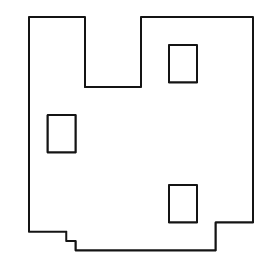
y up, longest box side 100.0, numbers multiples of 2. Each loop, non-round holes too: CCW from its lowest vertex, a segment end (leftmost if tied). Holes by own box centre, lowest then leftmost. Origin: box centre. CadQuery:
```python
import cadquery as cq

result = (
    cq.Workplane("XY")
    .moveTo(-28.0, -50.0)
    .lineTo(32.0, -50.0)
    .lineTo(32.0, -38.0)
    .lineTo(48.0, -38.0)
    .lineTo(48.0, 50.0)
    .lineTo(0.0, 50.0)
    .lineTo(0.0, 20.0)
    .lineTo(-24.0, 20.0)
    .lineTo(-24.0, 50.0)
    .lineTo(-48.0, 50.0)
    .lineTo(-48.0, -42.0)
    .lineTo(-32.0, -42.0)
    .lineTo(-32.0, -46.0)
    .lineTo(-28.0, -46.0)
    .close()
    .moveTo(12.0, -38.0)
    .lineTo(24.0, -38.0)
    .lineTo(24.0, -22.0)
    .lineTo(12.0, -22.0)
    .close()
    .moveTo(-40.0, -8.0)
    .lineTo(-28.0, -8.0)
    .lineTo(-28.0, 8.0)
    .lineTo(-40.0, 8.0)
    .close()
    .moveTo(12.0, 22.0)
    .lineTo(24.0, 22.0)
    .lineTo(24.0, 38.0)
    .lineTo(12.0, 38.0)
    .close()
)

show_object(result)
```